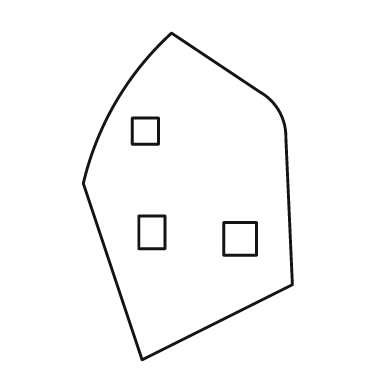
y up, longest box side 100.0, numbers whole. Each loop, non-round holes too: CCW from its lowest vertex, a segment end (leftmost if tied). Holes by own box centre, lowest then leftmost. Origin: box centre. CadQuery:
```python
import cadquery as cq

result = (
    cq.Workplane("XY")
    .moveTo(-14.0, -50.0)
    .lineTo(32.0, -27.0)
    .lineTo(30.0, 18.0)
    .threePointArc((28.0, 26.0), (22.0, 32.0))
    .lineTo(-5.0, 50.0)
    .threePointArc((-22.0, 29.0), (-32.0, 4.0))
    .close()
    .moveTo(11.0, -18.0)
    .lineTo(21.0, -18.0)
    .lineTo(21.0, -8.0)
    .lineTo(11.0, -8.0)
    .close()
    .moveTo(-15.0, -16.0)
    .lineTo(-7.0, -16.0)
    .lineTo(-7.0, -6.0)
    .lineTo(-15.0, -6.0)
    .close()
    .moveTo(-17.0, 16.0)
    .lineTo(-9.0, 16.0)
    .lineTo(-9.0, 24.0)
    .lineTo(-17.0, 24.0)
    .close()
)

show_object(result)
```